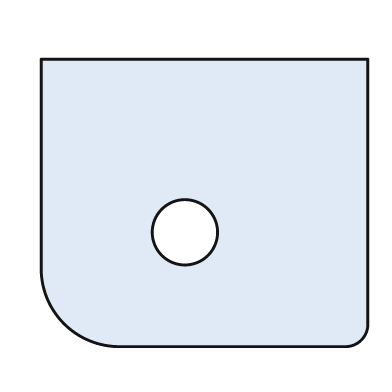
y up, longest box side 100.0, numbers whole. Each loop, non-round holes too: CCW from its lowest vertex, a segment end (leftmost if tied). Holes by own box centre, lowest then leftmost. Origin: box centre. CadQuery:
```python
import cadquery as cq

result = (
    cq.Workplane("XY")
    .moveTo(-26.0, -44.0)
    .lineTo(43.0, -44.0)
    .threePointArc((48.0, -42.0), (50.0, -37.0))
    .lineTo(50.0, 44.0)
    .lineTo(-50.0, 44.0)
    .lineTo(-50.0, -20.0)
    .threePointArc((-43.0, -37.0), (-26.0, -44.0))
    .close()
    .moveTo(-6.0, -9.0)
    .circle(10.0)
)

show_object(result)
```